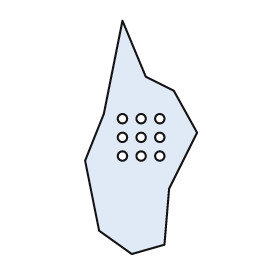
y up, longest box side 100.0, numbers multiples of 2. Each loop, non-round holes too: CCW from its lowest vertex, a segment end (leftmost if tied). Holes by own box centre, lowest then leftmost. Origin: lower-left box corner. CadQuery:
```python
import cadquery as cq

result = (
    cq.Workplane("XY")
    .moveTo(20.0, 0.0)
    .lineTo(34.0, 4.0)
    .lineTo(36.0, 28.0)
    .lineTo(48.0, 52.0)
    .lineTo(38.0, 70.0)
    .lineTo(26.0, 76.0)
    .lineTo(16.0, 100.0)
    .lineTo(8.0, 60.0)
    .lineTo(0.0, 40.0)
    .lineTo(6.0, 10.0)
    .close()
    .moveTo(16.0, 42.0)
    .circle(2.0)
    .moveTo(24.0, 42.0)
    .circle(2.0)
    .moveTo(32.0, 42.0)
    .circle(2.0)
    .moveTo(16.0, 50.0)
    .circle(2.0)
    .moveTo(24.0, 50.0)
    .circle(2.0)
    .moveTo(32.0, 50.0)
    .circle(2.0)
    .moveTo(16.0, 58.0)
    .circle(2.0)
    .moveTo(24.0, 58.0)
    .circle(2.0)
    .moveTo(32.0, 58.0)
    .circle(2.0)
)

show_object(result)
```